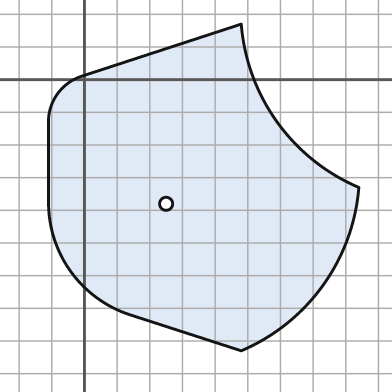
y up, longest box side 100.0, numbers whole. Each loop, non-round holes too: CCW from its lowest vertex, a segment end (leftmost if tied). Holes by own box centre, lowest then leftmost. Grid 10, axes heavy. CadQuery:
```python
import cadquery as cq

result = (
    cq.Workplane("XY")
    .moveTo(48.0, -83.0)
    .threePointArc((73.0, -63.0), (84.0, -33.0))
    .threePointArc((59.0, -13.0), (48.0, 17.0))
    .lineTo(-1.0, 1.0)
    .threePointArc((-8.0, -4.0), (-11.0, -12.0))
    .lineTo(-11.0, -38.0)
    .threePointArc((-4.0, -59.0), (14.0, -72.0))
    .close()
    .moveTo(25.0, -38.0)
    .circle(2.0)
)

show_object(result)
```